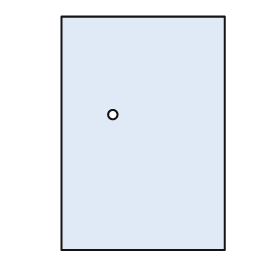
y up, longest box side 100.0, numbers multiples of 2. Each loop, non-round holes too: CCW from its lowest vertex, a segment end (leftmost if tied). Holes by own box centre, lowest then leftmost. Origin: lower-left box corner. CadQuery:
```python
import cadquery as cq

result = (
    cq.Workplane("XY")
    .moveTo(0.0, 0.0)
    .lineTo(70.0, 0.0)
    .lineTo(70.0, 100.0)
    .lineTo(0.0, 100.0)
    .close()
    .moveTo(22.0, 58.0)
    .circle(2.0)
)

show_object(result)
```